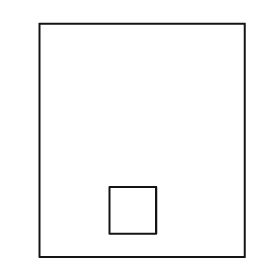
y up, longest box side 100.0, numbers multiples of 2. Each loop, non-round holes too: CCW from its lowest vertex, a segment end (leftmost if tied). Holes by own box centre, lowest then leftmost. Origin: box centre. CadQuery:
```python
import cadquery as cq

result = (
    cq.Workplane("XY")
    .moveTo(-44.0, -50.0)
    .lineTo(44.0, -50.0)
    .lineTo(44.0, 50.0)
    .lineTo(-44.0, 50.0)
    .close()
    .moveTo(-14.0, -40.0)
    .lineTo(6.0, -40.0)
    .lineTo(6.0, -20.0)
    .lineTo(-14.0, -20.0)
    .close()
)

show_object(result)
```